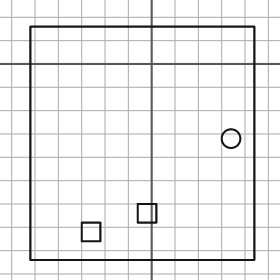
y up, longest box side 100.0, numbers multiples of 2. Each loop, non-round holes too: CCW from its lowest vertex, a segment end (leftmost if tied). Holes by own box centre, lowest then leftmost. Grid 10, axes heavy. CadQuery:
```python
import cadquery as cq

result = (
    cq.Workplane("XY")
    .moveTo(-52.0, -84.0)
    .lineTo(44.0, -84.0)
    .lineTo(44.0, 16.0)
    .lineTo(-52.0, 16.0)
    .close()
    .moveTo(-30.0, -76.0)
    .lineTo(-22.0, -76.0)
    .lineTo(-22.0, -68.0)
    .lineTo(-30.0, -68.0)
    .close()
    .moveTo(-6.0, -68.0)
    .lineTo(2.0, -68.0)
    .lineTo(2.0, -60.0)
    .lineTo(-6.0, -60.0)
    .close()
    .moveTo(34.0, -32.0)
    .circle(4.0)
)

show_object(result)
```